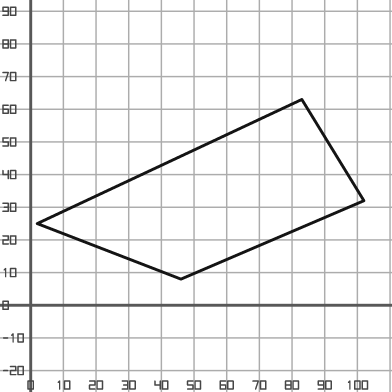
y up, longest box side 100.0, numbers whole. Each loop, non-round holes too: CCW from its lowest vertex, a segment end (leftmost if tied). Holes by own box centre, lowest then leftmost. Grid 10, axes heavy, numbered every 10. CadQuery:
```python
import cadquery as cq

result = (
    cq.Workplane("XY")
    .moveTo(46.0, 8.0)
    .lineTo(102.0, 32.0)
    .lineTo(83.0, 63.0)
    .lineTo(2.0, 25.0)
    .close()
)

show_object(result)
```